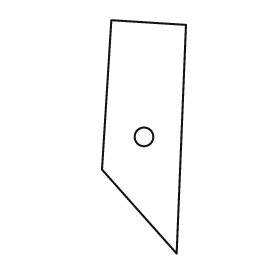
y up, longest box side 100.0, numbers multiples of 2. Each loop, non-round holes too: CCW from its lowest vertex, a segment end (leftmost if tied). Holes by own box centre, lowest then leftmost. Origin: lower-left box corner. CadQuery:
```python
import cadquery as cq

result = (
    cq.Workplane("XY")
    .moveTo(32.0, 0.0)
    .lineTo(36.0, 98.0)
    .lineTo(4.0, 100.0)
    .lineTo(0.0, 36.0)
    .close()
    .moveTo(18.0, 50.0)
    .circle(4.0)
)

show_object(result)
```